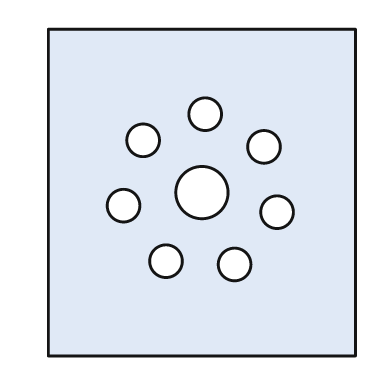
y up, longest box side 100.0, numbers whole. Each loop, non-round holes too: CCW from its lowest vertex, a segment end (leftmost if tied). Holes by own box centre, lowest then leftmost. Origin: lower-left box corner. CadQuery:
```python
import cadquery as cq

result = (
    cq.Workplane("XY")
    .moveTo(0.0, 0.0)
    .lineTo(94.0, 0.0)
    .lineTo(94.0, 100.0)
    .lineTo(0.0, 100.0)
    .close()
    .moveTo(57.0, 28.0)
    .circle(5.0)
    .moveTo(36.0, 29.0)
    .circle(5.0)
    .moveTo(70.0, 44.0)
    .circle(5.0)
    .moveTo(23.0, 46.0)
    .circle(5.0)
    .moveTo(47.0, 50.0)
    .circle(8.0)
    .moveTo(66.0, 64.0)
    .circle(5.0)
    .moveTo(29.0, 66.0)
    .circle(5.0)
    .moveTo(48.0, 74.0)
    .circle(5.0)
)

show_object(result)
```